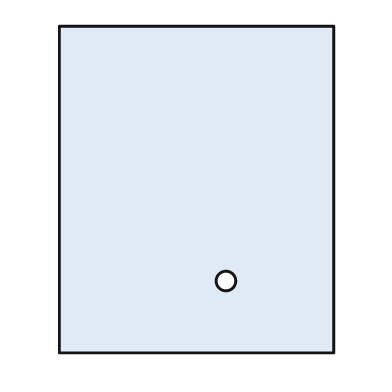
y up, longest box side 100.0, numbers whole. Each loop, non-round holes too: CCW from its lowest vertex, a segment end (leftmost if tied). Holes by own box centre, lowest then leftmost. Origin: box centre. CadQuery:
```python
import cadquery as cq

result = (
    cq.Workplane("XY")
    .moveTo(-42.0, -50.0)
    .lineTo(42.0, -50.0)
    .lineTo(42.0, 50.0)
    .lineTo(-42.0, 50.0)
    .close()
    .moveTo(9.0, -28.0)
    .circle(3.0)
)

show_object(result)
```